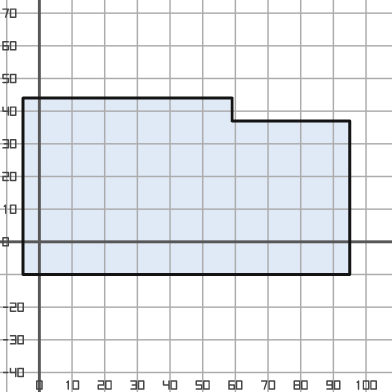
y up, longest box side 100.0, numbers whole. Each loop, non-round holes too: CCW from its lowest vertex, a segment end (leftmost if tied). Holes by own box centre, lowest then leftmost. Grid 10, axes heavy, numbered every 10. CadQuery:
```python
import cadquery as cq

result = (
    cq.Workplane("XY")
    .moveTo(-5.0, -10.0)
    .lineTo(95.0, -10.0)
    .lineTo(95.0, 37.0)
    .lineTo(59.0, 37.0)
    .lineTo(59.0, 44.0)
    .lineTo(-5.0, 44.0)
    .close()
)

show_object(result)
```